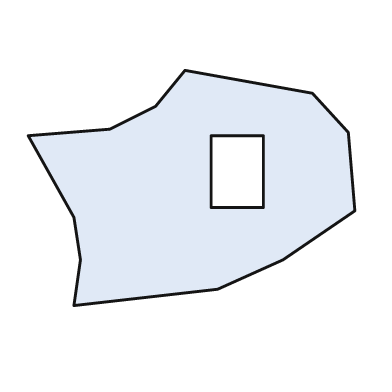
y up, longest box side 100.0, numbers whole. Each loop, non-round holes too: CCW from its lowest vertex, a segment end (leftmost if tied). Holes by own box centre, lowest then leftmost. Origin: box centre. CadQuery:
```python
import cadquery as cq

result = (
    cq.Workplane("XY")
    .moveTo(-36.0, -36.0)
    .lineTo(8.0, -31.0)
    .lineTo(28.0, -22.0)
    .lineTo(50.0, -7.0)
    .lineTo(48.0, 17.0)
    .lineTo(37.0, 29.0)
    .lineTo(-2.0, 36.0)
    .lineTo(-11.0, 25.0)
    .lineTo(-25.0, 18.0)
    .lineTo(-50.0, 16.0)
    .lineTo(-36.0, -9.0)
    .lineTo(-34.0, -22.0)
    .close()
    .moveTo(6.0, -6.0)
    .lineTo(22.0, -6.0)
    .lineTo(22.0, 16.0)
    .lineTo(6.0, 16.0)
    .close()
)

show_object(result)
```